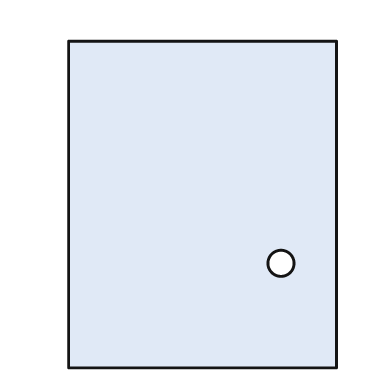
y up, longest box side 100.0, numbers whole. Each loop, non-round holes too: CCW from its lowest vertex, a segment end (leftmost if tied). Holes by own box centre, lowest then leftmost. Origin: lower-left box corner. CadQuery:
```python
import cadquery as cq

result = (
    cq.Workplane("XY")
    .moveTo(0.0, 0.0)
    .lineTo(82.0, 0.0)
    .lineTo(82.0, 100.0)
    .lineTo(0.0, 100.0)
    .close()
    .moveTo(65.0, 32.0)
    .circle(4.0)
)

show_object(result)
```